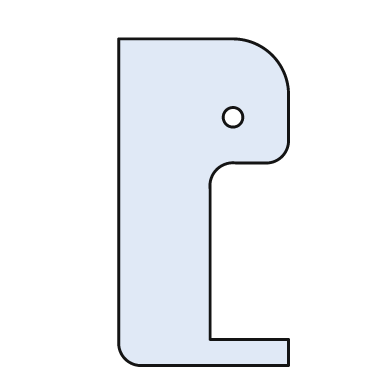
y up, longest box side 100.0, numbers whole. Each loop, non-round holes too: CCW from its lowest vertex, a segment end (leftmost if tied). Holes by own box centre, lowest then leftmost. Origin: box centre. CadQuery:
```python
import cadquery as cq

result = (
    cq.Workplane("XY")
    .moveTo(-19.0, -50.0)
    .lineTo(26.0, -50.0)
    .lineTo(26.0, -42.0)
    .lineTo(2.0, -42.0)
    .lineTo(2.0, 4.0)
    .threePointArc((4.0, 10.0), (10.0, 12.0))
    .lineTo(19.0, 12.0)
    .threePointArc((24.0, 14.0), (26.0, 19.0))
    .lineTo(26.0, 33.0)
    .threePointArc((21.0, 45.0), (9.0, 50.0))
    .lineTo(-26.0, 50.0)
    .lineTo(-26.0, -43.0)
    .threePointArc((-24.0, -48.0), (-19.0, -50.0))
    .close()
    .moveTo(9.0, 26.0)
    .circle(3.0)
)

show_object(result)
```